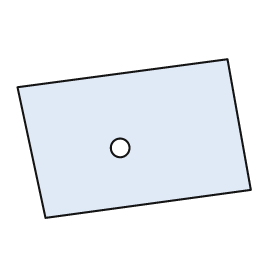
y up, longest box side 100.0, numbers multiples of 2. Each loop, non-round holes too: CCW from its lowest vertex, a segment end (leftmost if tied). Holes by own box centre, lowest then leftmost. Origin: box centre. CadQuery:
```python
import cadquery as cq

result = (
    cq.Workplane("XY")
    .moveTo(-38.0, -34.0)
    .lineTo(50.0, -22.0)
    .lineTo(40.0, 34.0)
    .lineTo(-50.0, 22.0)
    .close()
    .moveTo(-6.0, -4.0)
    .circle(4.0)
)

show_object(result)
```